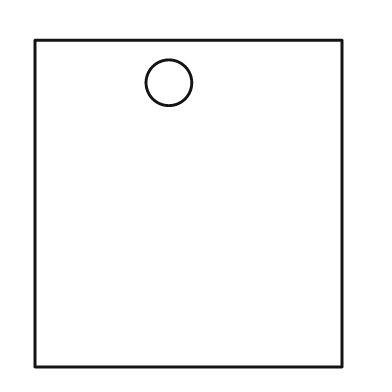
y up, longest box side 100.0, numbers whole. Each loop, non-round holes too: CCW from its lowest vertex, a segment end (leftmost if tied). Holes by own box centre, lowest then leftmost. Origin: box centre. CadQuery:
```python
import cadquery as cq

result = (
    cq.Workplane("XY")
    .moveTo(-47.0, -50.0)
    .lineTo(47.0, -50.0)
    .lineTo(47.0, 50.0)
    .lineTo(-47.0, 50.0)
    .close()
    .moveTo(-6.0, 37.0)
    .circle(7.0)
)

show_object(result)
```